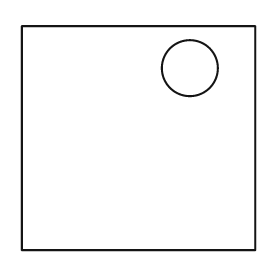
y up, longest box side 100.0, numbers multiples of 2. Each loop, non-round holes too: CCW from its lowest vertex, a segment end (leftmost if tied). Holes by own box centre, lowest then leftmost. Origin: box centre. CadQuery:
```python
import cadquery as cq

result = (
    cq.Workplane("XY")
    .moveTo(-50.0, -48.0)
    .lineTo(50.0, -48.0)
    .lineTo(50.0, 48.0)
    .lineTo(-50.0, 48.0)
    .close()
    .moveTo(22.0, 30.0)
    .circle(12.0)
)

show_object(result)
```